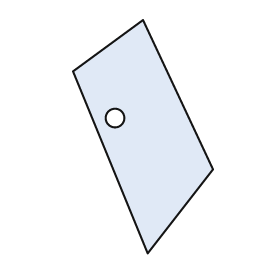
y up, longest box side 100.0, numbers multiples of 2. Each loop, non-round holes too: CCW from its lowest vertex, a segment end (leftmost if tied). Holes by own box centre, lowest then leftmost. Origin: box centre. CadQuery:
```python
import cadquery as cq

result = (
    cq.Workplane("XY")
    .moveTo(2.0, -50.0)
    .lineTo(30.0, -14.0)
    .lineTo(0.0, 50.0)
    .lineTo(-30.0, 28.0)
    .close()
    .moveTo(-12.0, 8.0)
    .circle(4.0)
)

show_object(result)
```